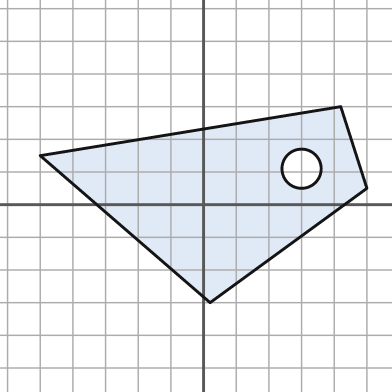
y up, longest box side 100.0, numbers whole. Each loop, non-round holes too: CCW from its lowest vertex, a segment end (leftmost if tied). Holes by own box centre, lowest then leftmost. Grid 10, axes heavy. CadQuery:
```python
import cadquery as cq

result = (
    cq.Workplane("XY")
    .moveTo(2.0, -30.0)
    .lineTo(50.0, 5.0)
    .lineTo(42.0, 30.0)
    .lineTo(-50.0, 15.0)
    .close()
    .moveTo(30.0, 11.0)
    .circle(6.0)
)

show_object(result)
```